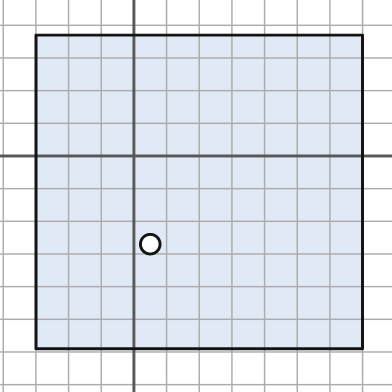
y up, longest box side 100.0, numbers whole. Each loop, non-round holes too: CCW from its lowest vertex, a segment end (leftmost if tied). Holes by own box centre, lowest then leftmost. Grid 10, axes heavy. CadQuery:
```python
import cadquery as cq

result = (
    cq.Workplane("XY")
    .moveTo(-30.0, -59.0)
    .lineTo(70.0, -59.0)
    .lineTo(70.0, 37.0)
    .lineTo(-30.0, 37.0)
    .close()
    .moveTo(5.0, -27.0)
    .circle(3.0)
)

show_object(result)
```